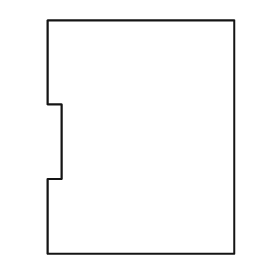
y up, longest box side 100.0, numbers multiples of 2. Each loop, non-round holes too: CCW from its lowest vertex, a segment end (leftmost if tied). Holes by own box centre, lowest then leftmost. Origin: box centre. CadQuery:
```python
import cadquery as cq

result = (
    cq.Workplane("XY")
    .moveTo(-40.0, -50.0)
    .lineTo(40.0, -50.0)
    .lineTo(40.0, 50.0)
    .lineTo(-40.0, 50.0)
    .lineTo(-40.0, 14.0)
    .lineTo(-34.0, 14.0)
    .lineTo(-34.0, -18.0)
    .lineTo(-40.0, -18.0)
    .close()
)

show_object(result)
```